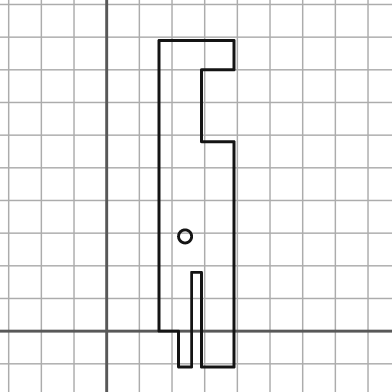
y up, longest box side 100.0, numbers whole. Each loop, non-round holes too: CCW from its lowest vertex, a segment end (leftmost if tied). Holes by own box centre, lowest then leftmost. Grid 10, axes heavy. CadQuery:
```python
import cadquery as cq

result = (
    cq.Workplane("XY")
    .moveTo(22.0, -11.0)
    .lineTo(26.0, -11.0)
    .lineTo(26.0, 18.0)
    .lineTo(29.0, 18.0)
    .lineTo(29.0, -11.0)
    .lineTo(39.0, -11.0)
    .lineTo(39.0, 58.0)
    .lineTo(29.0, 58.0)
    .lineTo(29.0, 80.0)
    .lineTo(39.0, 80.0)
    .lineTo(39.0, 89.0)
    .lineTo(16.0, 89.0)
    .lineTo(16.0, 0.0)
    .lineTo(22.0, 0.0)
    .close()
    .moveTo(24.0, 29.0)
    .circle(2.0)
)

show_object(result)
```